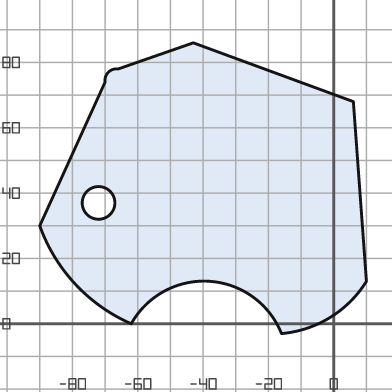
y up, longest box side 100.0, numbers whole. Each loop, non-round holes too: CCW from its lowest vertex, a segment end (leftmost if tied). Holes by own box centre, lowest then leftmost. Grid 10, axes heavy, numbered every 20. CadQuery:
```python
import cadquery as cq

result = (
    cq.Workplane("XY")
    .moveTo(-16.0, -3.0)
    .threePointArc((-1.0, 2.0), (10.0, 13.0))
    .lineTo(6.0, 68.0)
    .lineTo(-43.0, 86.0)
    .lineTo(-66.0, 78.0)
    .threePointArc((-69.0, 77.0), (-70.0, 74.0))
    .lineTo(-90.0, 30.0)
    .threePointArc((-79.0, 12.0), (-62.0, 0.0))
    .threePointArc((-38.0, 13.0), (-16.0, -3.0))
    .close()
    .moveTo(-72.0, 37.0)
    .circle(5.0)
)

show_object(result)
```